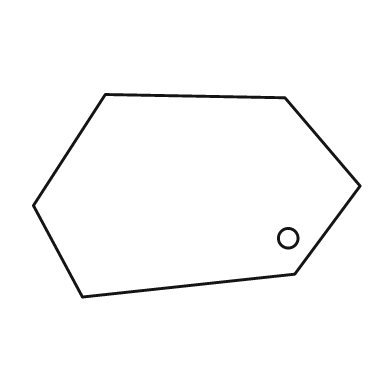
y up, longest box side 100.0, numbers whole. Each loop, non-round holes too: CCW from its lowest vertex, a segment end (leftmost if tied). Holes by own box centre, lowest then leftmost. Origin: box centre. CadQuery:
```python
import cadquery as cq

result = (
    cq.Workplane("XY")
    .moveTo(-35.0, -31.0)
    .lineTo(30.0, -24.0)
    .lineTo(50.0, 3.0)
    .lineTo(27.0, 30.0)
    .lineTo(-28.0, 31.0)
    .lineTo(-50.0, -3.0)
    .close()
    .moveTo(28.0, -13.0)
    .circle(3.0)
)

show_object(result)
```